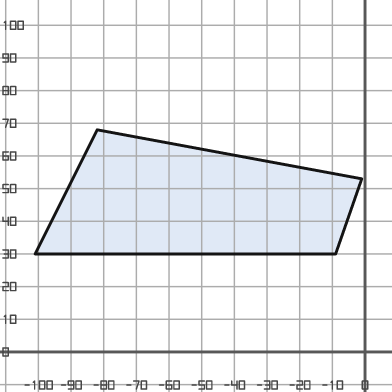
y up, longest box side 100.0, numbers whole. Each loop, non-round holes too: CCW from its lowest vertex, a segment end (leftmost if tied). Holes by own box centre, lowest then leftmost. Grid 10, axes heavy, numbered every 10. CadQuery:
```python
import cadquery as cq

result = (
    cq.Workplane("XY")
    .moveTo(-101.0, 30.0)
    .lineTo(-9.0, 30.0)
    .lineTo(-1.0, 53.0)
    .lineTo(-82.0, 68.0)
    .close()
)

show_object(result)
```